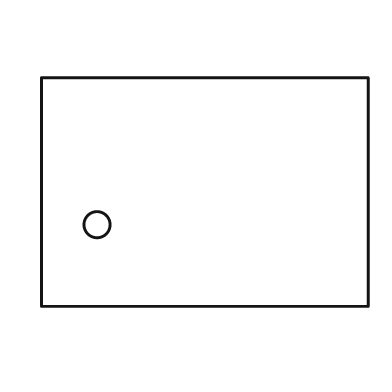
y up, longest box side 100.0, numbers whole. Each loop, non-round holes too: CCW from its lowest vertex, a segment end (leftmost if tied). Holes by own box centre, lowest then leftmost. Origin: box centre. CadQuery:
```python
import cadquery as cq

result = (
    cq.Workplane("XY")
    .moveTo(-50.0, -35.0)
    .lineTo(50.0, -35.0)
    .lineTo(50.0, 35.0)
    .lineTo(-50.0, 35.0)
    .close()
    .moveTo(-33.0, -10.0)
    .circle(4.0)
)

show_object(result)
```